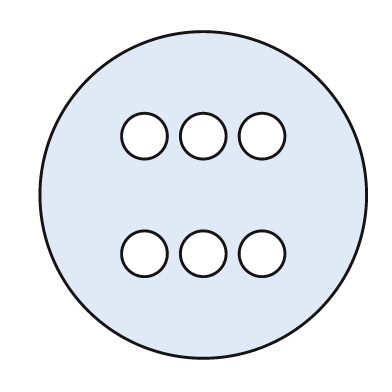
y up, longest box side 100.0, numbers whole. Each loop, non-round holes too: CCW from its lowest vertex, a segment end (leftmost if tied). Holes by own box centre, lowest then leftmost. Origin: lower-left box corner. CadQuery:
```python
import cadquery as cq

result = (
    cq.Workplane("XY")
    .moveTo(50.0, 50.0)
    .circle(50.0)
    .moveTo(32.0, 32.0)
    .circle(7.0)
    .moveTo(50.0, 32.0)
    .circle(7.0)
    .moveTo(68.0, 32.0)
    .circle(7.0)
    .moveTo(32.0, 68.0)
    .circle(7.0)
    .moveTo(50.0, 68.0)
    .circle(7.0)
    .moveTo(68.0, 68.0)
    .circle(7.0)
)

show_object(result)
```